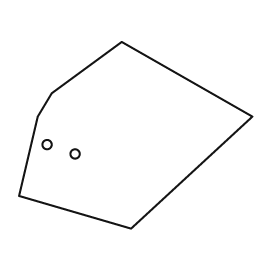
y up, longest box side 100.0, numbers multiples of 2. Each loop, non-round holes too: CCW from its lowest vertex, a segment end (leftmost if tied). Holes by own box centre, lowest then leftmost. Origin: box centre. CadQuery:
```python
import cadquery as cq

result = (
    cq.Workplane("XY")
    .moveTo(-2.0, -40.0)
    .lineTo(50.0, 8.0)
    .lineTo(-6.0, 40.0)
    .lineTo(-36.0, 18.0)
    .lineTo(-42.0, 8.0)
    .lineTo(-50.0, -26.0)
    .close()
    .moveTo(-26.0, -8.0)
    .circle(2.0)
    .moveTo(-38.0, -4.0)
    .circle(2.0)
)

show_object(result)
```